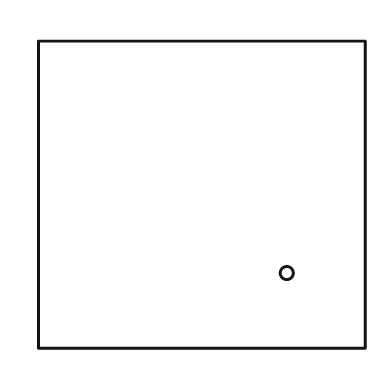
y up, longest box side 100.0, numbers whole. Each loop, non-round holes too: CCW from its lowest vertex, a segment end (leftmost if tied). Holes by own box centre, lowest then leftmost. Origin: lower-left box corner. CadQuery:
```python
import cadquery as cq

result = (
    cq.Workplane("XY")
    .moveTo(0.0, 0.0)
    .lineTo(100.0, 0.0)
    .lineTo(100.0, 94.0)
    .lineTo(0.0, 94.0)
    .close()
    .moveTo(76.0, 23.0)
    .circle(2.0)
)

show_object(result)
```